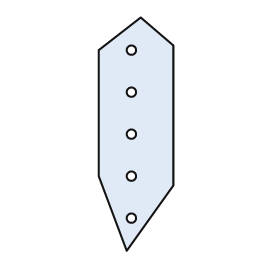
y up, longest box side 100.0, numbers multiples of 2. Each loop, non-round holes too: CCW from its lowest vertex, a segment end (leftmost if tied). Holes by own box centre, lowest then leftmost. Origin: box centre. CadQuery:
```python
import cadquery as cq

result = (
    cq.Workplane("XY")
    .moveTo(-4.0, -50.0)
    .lineTo(16.0, -22.0)
    .lineTo(16.0, 38.0)
    .lineTo(2.0, 50.0)
    .lineTo(-16.0, 36.0)
    .lineTo(-16.0, -18.0)
    .close()
    .moveTo(-2.0, -36.0)
    .circle(2.0)
    .moveTo(-2.0, -18.0)
    .circle(2.0)
    .moveTo(-2.0, 0.0)
    .circle(2.0)
    .moveTo(-2.0, 18.0)
    .circle(2.0)
    .moveTo(-2.0, 36.0)
    .circle(2.0)
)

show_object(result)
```